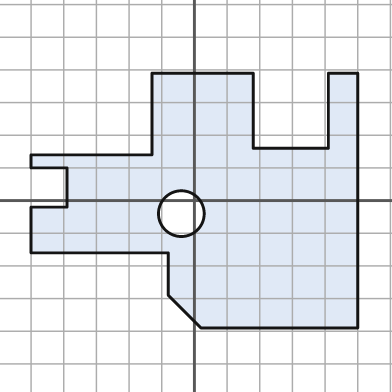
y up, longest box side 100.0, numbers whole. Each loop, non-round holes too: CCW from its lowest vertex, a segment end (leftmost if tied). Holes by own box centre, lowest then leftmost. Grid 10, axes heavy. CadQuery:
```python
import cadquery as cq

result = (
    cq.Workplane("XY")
    .moveTo(2.0, -39.0)
    .lineTo(50.0, -39.0)
    .lineTo(50.0, 39.0)
    .lineTo(41.0, 39.0)
    .lineTo(41.0, 16.0)
    .lineTo(18.0, 16.0)
    .lineTo(18.0, 39.0)
    .lineTo(-13.0, 39.0)
    .lineTo(-13.0, 14.0)
    .lineTo(-50.0, 14.0)
    .lineTo(-50.0, 10.0)
    .lineTo(-39.0, 10.0)
    .lineTo(-39.0, -2.0)
    .lineTo(-50.0, -2.0)
    .lineTo(-50.0, -16.0)
    .lineTo(-8.0, -16.0)
    .lineTo(-8.0, -29.0)
    .close()
    .moveTo(-4.0, -4.0)
    .circle(7.0)
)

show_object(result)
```